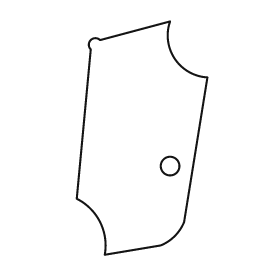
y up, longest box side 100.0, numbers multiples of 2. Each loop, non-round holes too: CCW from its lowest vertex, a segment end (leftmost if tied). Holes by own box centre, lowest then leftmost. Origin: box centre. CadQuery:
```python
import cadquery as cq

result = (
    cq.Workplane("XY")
    .moveTo(-16.0, -50.0)
    .lineTo(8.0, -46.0)
    .threePointArc((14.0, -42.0), (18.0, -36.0))
    .lineTo(28.0, 26.0)
    .threePointArc((14.0, 34.0), (12.0, 50.0))
    .lineTo(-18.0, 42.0)
    .threePointArc((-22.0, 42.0), (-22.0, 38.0))
    .lineTo(-28.0, -26.0)
    .threePointArc((-18.0, -36.0), (-16.0, -50.0))
    .close()
    .moveTo(12.0, -12.0)
    .circle(4.0)
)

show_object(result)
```